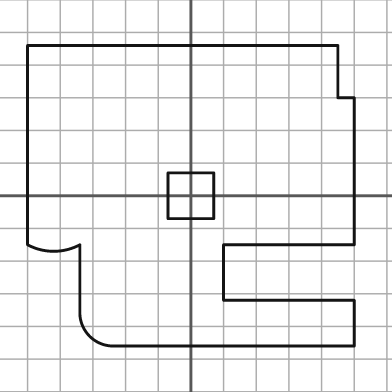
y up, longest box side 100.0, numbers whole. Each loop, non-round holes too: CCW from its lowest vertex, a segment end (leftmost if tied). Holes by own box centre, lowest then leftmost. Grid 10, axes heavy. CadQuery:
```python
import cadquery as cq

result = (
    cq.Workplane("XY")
    .moveTo(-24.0, -46.0)
    .lineTo(50.0, -46.0)
    .lineTo(50.0, -32.0)
    .lineTo(10.0, -32.0)
    .lineTo(10.0, -15.0)
    .lineTo(50.0, -15.0)
    .lineTo(50.0, 30.0)
    .lineTo(45.0, 30.0)
    .lineTo(45.0, 46.0)
    .lineTo(-50.0, 46.0)
    .lineTo(-50.0, -15.0)
    .threePointArc((-42.0, -17.0), (-34.0, -15.0))
    .lineTo(-34.0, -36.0)
    .threePointArc((-31.0, -43.0), (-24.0, -46.0))
    .close()
    .moveTo(-7.0, -7.0)
    .lineTo(7.0, -7.0)
    .lineTo(7.0, 7.0)
    .lineTo(-7.0, 7.0)
    .close()
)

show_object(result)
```